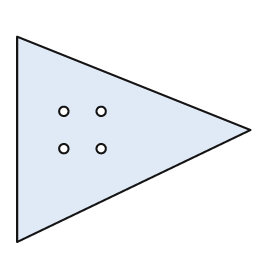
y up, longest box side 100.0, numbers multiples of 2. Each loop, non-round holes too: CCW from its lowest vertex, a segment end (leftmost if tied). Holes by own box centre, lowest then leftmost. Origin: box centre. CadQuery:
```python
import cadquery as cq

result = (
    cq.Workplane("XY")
    .moveTo(-50.0, -44.0)
    .lineTo(50.0, 4.0)
    .lineTo(-50.0, 44.0)
    .close()
    .moveTo(-30.0, -4.0)
    .circle(2.0)
    .moveTo(-14.0, -4.0)
    .circle(2.0)
    .moveTo(-30.0, 12.0)
    .circle(2.0)
    .moveTo(-14.0, 12.0)
    .circle(2.0)
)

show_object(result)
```